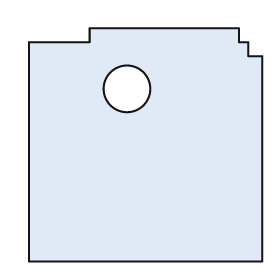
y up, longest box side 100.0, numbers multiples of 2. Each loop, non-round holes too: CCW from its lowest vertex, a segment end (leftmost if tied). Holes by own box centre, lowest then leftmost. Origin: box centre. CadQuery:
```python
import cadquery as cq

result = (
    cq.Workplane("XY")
    .moveTo(-50.0, -50.0)
    .lineTo(50.0, -50.0)
    .lineTo(50.0, 38.0)
    .lineTo(44.0, 38.0)
    .lineTo(44.0, 44.0)
    .lineTo(40.0, 44.0)
    .lineTo(40.0, 50.0)
    .lineTo(-24.0, 50.0)
    .lineTo(-24.0, 44.0)
    .lineTo(-50.0, 44.0)
    .close()
    .moveTo(-8.0, 24.0)
    .circle(10.0)
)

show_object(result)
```